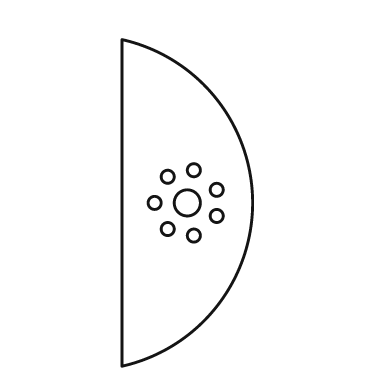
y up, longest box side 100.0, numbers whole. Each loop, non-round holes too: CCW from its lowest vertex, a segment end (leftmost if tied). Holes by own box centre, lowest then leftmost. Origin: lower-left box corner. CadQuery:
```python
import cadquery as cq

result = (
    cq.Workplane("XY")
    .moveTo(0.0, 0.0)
    .threePointArc((40.0, 50.0), (0.0, 100.0))
    .close()
    .moveTo(22.0, 40.0)
    .circle(2.0)
    .moveTo(14.0, 42.0)
    .circle(2.0)
    .moveTo(29.0, 46.0)
    .circle(2.0)
    .moveTo(10.0, 50.0)
    .circle(2.0)
    .moveTo(20.0, 50.0)
    .circle(4.0)
    .moveTo(29.0, 54.0)
    .circle(2.0)
    .moveTo(14.0, 58.0)
    .circle(2.0)
    .moveTo(22.0, 60.0)
    .circle(2.0)
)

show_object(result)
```